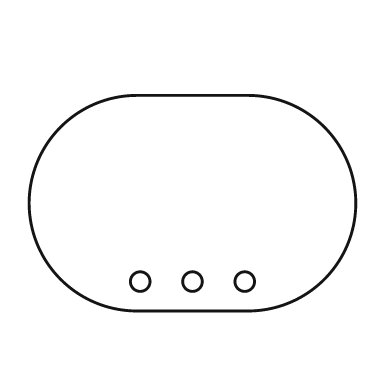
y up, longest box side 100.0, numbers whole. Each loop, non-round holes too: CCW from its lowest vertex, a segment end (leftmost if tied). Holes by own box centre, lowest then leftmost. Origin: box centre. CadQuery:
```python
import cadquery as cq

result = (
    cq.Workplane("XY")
    .moveTo(-17.0, -33.0)
    .lineTo(17.0, -33.0)
    .threePointArc((50.0, 0.0), (17.0, 33.0))
    .lineTo(-17.0, 33.0)
    .threePointArc((-50.0, 0.0), (-17.0, -33.0))
    .close()
    .moveTo(-16.0, -24.0)
    .circle(3.0)
    .moveTo(0.0, -24.0)
    .circle(3.0)
    .moveTo(16.0, -24.0)
    .circle(3.0)
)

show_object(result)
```